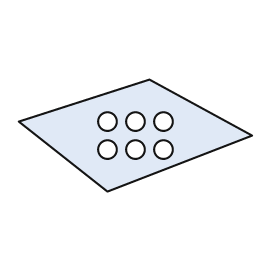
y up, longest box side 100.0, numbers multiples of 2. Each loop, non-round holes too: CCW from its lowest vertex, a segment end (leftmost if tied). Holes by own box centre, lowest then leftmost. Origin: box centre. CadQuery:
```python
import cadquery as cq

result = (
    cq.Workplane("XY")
    .moveTo(-12.0, -24.0)
    .lineTo(50.0, 0.0)
    .lineTo(6.0, 24.0)
    .lineTo(-50.0, 6.0)
    .close()
    .moveTo(-12.0, -6.0)
    .circle(4.0)
    .moveTo(0.0, -6.0)
    .circle(4.0)
    .moveTo(12.0, -6.0)
    .circle(4.0)
    .moveTo(-12.0, 6.0)
    .circle(4.0)
    .moveTo(0.0, 6.0)
    .circle(4.0)
    .moveTo(12.0, 6.0)
    .circle(4.0)
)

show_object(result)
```